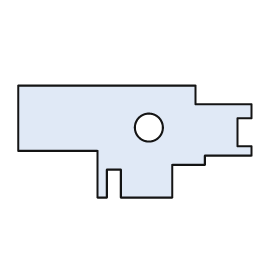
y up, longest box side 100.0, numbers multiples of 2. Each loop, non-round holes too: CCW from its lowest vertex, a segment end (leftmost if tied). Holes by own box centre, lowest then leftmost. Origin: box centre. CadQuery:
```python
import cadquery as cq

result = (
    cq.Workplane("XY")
    .moveTo(-16.0, -24.0)
    .lineTo(-12.0, -24.0)
    .lineTo(-12.0, -12.0)
    .lineTo(-6.0, -12.0)
    .lineTo(-6.0, -24.0)
    .lineTo(16.0, -24.0)
    .lineTo(16.0, -10.0)
    .lineTo(30.0, -10.0)
    .lineTo(30.0, -6.0)
    .lineTo(50.0, -6.0)
    .lineTo(50.0, -2.0)
    .lineTo(44.0, -2.0)
    .lineTo(44.0, 10.0)
    .lineTo(50.0, 10.0)
    .lineTo(50.0, 16.0)
    .lineTo(26.0, 16.0)
    .lineTo(26.0, 24.0)
    .lineTo(-50.0, 24.0)
    .lineTo(-50.0, -4.0)
    .lineTo(-16.0, -4.0)
    .close()
    .moveTo(6.0, 6.0)
    .circle(6.0)
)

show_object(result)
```